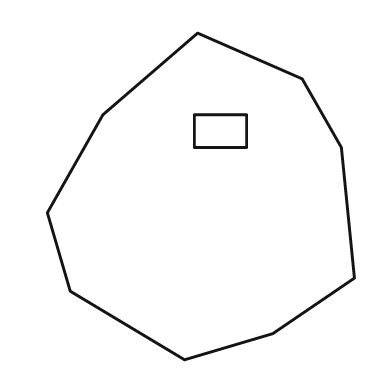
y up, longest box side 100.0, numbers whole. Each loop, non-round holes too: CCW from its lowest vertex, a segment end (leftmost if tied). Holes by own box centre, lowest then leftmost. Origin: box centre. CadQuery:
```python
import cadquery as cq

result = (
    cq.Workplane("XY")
    .moveTo(-5.0, -50.0)
    .lineTo(22.0, -42.0)
    .lineTo(47.0, -25.0)
    .lineTo(43.0, 15.0)
    .lineTo(31.0, 36.0)
    .lineTo(-1.0, 50.0)
    .lineTo(-30.0, 25.0)
    .lineTo(-47.0, -5.0)
    .lineTo(-40.0, -29.0)
    .close()
    .moveTo(-2.0, 15.0)
    .lineTo(14.0, 15.0)
    .lineTo(14.0, 25.0)
    .lineTo(-2.0, 25.0)
    .close()
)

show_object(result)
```